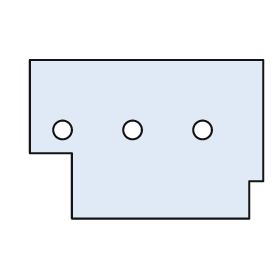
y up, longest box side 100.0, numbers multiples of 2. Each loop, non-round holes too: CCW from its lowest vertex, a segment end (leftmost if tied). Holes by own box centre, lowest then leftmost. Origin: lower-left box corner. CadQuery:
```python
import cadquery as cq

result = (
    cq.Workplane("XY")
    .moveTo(18.0, 0.0)
    .lineTo(94.0, 0.0)
    .lineTo(94.0, 16.0)
    .lineTo(100.0, 16.0)
    .lineTo(100.0, 68.0)
    .lineTo(0.0, 68.0)
    .lineTo(0.0, 28.0)
    .lineTo(18.0, 28.0)
    .close()
    .moveTo(14.0, 38.0)
    .circle(4.0)
    .moveTo(44.0, 38.0)
    .circle(4.0)
    .moveTo(74.0, 38.0)
    .circle(4.0)
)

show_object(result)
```